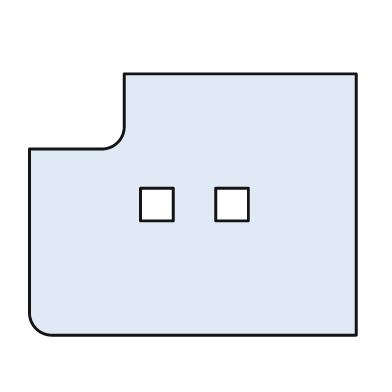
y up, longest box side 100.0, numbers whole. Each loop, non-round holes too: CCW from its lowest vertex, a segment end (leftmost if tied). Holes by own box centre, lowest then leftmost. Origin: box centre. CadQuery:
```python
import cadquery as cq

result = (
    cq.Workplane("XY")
    .moveTo(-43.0, -40.0)
    .lineTo(50.0, -40.0)
    .lineTo(50.0, 40.0)
    .lineTo(-21.0, 40.0)
    .lineTo(-21.0, 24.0)
    .threePointArc((-23.0, 19.0), (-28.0, 17.0))
    .lineTo(-50.0, 17.0)
    .lineTo(-50.0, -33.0)
    .threePointArc((-48.0, -38.0), (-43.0, -40.0))
    .close()
    .moveTo(-16.0, -5.0)
    .lineTo(-6.0, -5.0)
    .lineTo(-6.0, 5.0)
    .lineTo(-16.0, 5.0)
    .close()
    .moveTo(7.0, -5.0)
    .lineTo(17.0, -5.0)
    .lineTo(17.0, 5.0)
    .lineTo(7.0, 5.0)
    .close()
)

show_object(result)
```